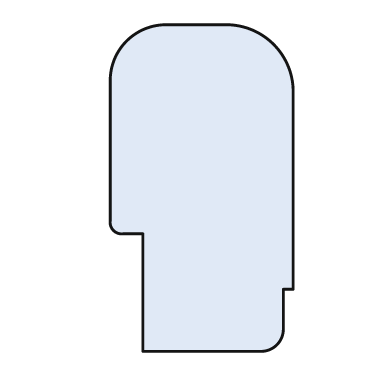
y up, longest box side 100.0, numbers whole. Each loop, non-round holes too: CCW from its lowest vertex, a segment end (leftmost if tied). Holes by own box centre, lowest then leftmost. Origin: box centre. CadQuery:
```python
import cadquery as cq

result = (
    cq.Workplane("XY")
    .moveTo(-18.0, -50.0)
    .lineTo(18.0, -50.0)
    .threePointArc((23.0, -48.0), (25.0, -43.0))
    .lineTo(25.0, -31.0)
    .lineTo(28.0, -31.0)
    .lineTo(28.0, 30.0)
    .threePointArc((22.0, 44.0), (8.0, 50.0))
    .lineTo(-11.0, 50.0)
    .threePointArc((-23.0, 45.0), (-28.0, 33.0))
    .lineTo(-28.0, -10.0)
    .threePointArc((-27.0, -13.0), (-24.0, -14.0))
    .lineTo(-18.0, -14.0)
    .close()
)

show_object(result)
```